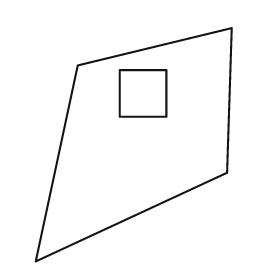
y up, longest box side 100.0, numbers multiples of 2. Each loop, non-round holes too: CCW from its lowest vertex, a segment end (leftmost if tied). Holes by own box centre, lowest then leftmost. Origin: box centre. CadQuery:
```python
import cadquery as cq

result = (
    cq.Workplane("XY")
    .moveTo(-42.0, -50.0)
    .lineTo(40.0, -12.0)
    .lineTo(42.0, 50.0)
    .lineTo(-24.0, 34.0)
    .close()
    .moveTo(-6.0, 12.0)
    .lineTo(14.0, 12.0)
    .lineTo(14.0, 32.0)
    .lineTo(-6.0, 32.0)
    .close()
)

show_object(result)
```